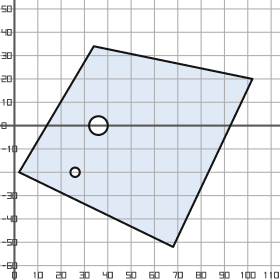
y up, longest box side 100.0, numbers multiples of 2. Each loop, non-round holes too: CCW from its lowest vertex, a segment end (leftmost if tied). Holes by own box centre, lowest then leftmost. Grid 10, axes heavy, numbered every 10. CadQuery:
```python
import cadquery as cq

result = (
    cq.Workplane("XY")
    .moveTo(68.0, -52.0)
    .lineTo(102.0, 20.0)
    .lineTo(34.0, 34.0)
    .lineTo(2.0, -20.0)
    .close()
    .moveTo(26.0, -20.0)
    .circle(2.0)
    .moveTo(36.0, 0.0)
    .circle(4.0)
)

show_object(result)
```